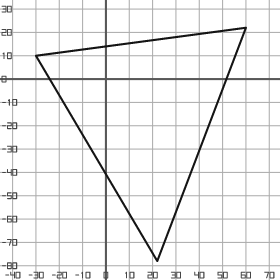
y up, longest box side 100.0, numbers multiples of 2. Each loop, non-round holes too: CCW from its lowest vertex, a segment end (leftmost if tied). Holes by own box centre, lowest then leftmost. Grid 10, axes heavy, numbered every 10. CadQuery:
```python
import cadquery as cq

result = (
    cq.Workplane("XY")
    .moveTo(22.0, -78.0)
    .lineTo(60.0, 22.0)
    .lineTo(-30.0, 10.0)
    .close()
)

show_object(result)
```